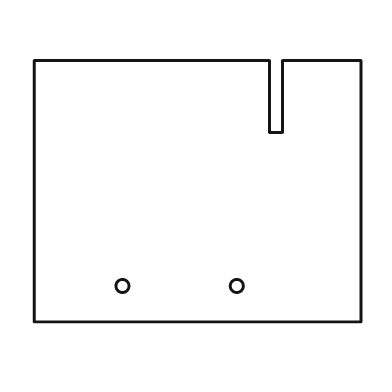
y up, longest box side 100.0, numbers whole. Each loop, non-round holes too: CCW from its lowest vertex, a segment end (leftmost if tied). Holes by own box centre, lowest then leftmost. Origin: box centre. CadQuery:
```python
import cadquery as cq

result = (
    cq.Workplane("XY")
    .moveTo(-50.0, -40.0)
    .lineTo(50.0, -40.0)
    .lineTo(50.0, 40.0)
    .lineTo(26.0, 40.0)
    .lineTo(26.0, 18.0)
    .lineTo(22.0, 18.0)
    .lineTo(22.0, 40.0)
    .lineTo(-50.0, 40.0)
    .close()
    .moveTo(-23.0, -29.0)
    .circle(2.0)
    .moveTo(12.0, -29.0)
    .circle(2.0)
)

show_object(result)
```